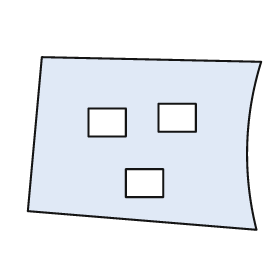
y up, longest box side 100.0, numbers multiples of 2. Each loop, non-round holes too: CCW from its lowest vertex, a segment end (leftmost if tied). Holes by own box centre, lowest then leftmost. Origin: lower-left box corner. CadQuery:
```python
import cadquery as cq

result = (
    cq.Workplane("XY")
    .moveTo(98.0, 0.0)
    .threePointArc((94.0, 36.0), (100.0, 72.0))
    .lineTo(6.0, 74.0)
    .lineTo(0.0, 8.0)
    .close()
    .moveTo(42.0, 14.0)
    .lineTo(58.0, 14.0)
    .lineTo(58.0, 26.0)
    .lineTo(42.0, 26.0)
    .close()
    .moveTo(26.0, 40.0)
    .lineTo(42.0, 40.0)
    .lineTo(42.0, 52.0)
    .lineTo(26.0, 52.0)
    .close()
    .moveTo(56.0, 42.0)
    .lineTo(72.0, 42.0)
    .lineTo(72.0, 54.0)
    .lineTo(56.0, 54.0)
    .close()
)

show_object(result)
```